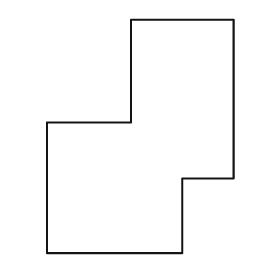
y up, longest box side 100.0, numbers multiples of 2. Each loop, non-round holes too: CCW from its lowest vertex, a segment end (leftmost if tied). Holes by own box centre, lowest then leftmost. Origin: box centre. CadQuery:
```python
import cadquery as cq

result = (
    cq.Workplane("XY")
    .moveTo(-40.0, -50.0)
    .lineTo(18.0, -50.0)
    .lineTo(18.0, -18.0)
    .lineTo(40.0, -18.0)
    .lineTo(40.0, 50.0)
    .lineTo(-4.0, 50.0)
    .lineTo(-4.0, 6.0)
    .lineTo(-40.0, 6.0)
    .close()
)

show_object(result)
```